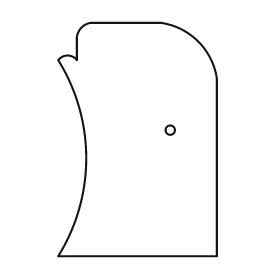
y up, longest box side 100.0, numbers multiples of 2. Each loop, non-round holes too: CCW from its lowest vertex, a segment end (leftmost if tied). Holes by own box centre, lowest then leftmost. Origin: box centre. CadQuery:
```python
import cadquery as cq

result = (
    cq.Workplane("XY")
    .moveTo(-34.0, -50.0)
    .lineTo(34.0, -50.0)
    .lineTo(34.0, 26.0)
    .threePointArc((26.0, 42.0), (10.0, 50.0))
    .lineTo(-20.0, 50.0)
    .threePointArc((-24.0, 48.0), (-26.0, 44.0))
    .lineTo(-26.0, 34.0)
    .threePointArc((-30.0, 36.0), (-34.0, 34.0))
    .threePointArc((-22.0, -8.0), (-34.0, -50.0))
    .close()
    .moveTo(14.0, 4.0)
    .circle(2.0)
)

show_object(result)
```